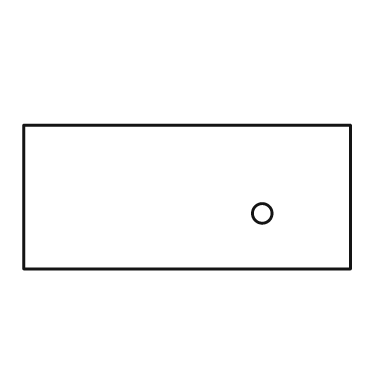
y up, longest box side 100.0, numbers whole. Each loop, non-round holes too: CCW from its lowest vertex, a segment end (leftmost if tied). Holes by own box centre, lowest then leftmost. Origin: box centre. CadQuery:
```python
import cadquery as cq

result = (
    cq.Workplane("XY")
    .moveTo(-50.0, -22.0)
    .lineTo(50.0, -22.0)
    .lineTo(50.0, 22.0)
    .lineTo(-50.0, 22.0)
    .close()
    .moveTo(23.0, -5.0)
    .circle(3.0)
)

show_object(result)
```